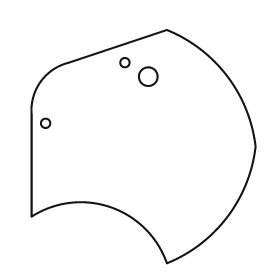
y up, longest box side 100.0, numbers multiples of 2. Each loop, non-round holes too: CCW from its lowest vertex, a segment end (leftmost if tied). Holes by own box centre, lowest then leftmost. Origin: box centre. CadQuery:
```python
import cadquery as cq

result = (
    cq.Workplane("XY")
    .moveTo(10.0, -50.0)
    .threePointArc((36.0, -30.0), (48.0, 0.0))
    .threePointArc((36.0, 30.0), (10.0, 50.0))
    .lineTo(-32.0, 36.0)
    .threePointArc((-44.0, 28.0), (-48.0, 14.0))
    .lineTo(-48.0, -30.0)
    .threePointArc((-14.0, -26.0), (10.0, -50.0))
    .close()
    .moveTo(-42.0, 10.0)
    .circle(2.0)
    .moveTo(2.0, 30.0)
    .circle(4.0)
    .moveTo(-8.0, 36.0)
    .circle(2.0)
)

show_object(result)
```